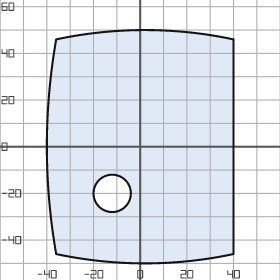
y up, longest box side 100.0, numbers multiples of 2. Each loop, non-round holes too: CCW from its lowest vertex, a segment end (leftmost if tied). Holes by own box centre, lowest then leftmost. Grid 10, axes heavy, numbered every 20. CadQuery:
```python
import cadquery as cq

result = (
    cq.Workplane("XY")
    .moveTo(-36.0, -46.0)
    .threePointArc((2.0, -50.0), (40.0, -46.0))
    .lineTo(40.0, 46.0)
    .threePointArc((2.0, 50.0), (-36.0, 46.0))
    .threePointArc((-40.0, 0.0), (-36.0, -46.0))
    .close()
    .moveTo(-12.0, -20.0)
    .circle(8.0)
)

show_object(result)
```